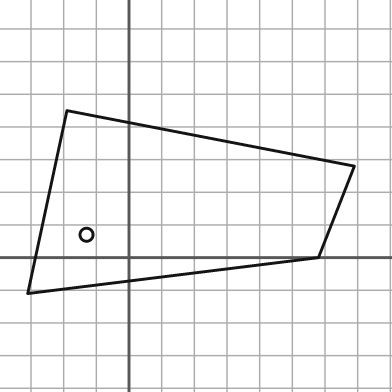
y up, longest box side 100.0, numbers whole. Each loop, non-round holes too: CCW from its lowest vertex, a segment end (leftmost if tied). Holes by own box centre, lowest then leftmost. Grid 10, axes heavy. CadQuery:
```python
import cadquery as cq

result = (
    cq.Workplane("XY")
    .moveTo(-31.0, -11.0)
    .lineTo(58.0, 0.0)
    .lineTo(69.0, 28.0)
    .lineTo(-19.0, 45.0)
    .close()
    .moveTo(-13.0, 7.0)
    .circle(2.0)
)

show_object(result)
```